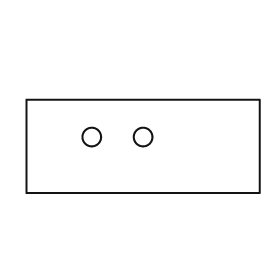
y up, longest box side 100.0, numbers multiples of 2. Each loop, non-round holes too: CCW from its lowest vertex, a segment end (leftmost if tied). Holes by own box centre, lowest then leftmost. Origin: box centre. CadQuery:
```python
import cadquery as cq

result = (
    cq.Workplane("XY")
    .moveTo(-50.0, -20.0)
    .lineTo(50.0, -20.0)
    .lineTo(50.0, 20.0)
    .lineTo(-50.0, 20.0)
    .close()
    .moveTo(-22.0, 4.0)
    .circle(4.0)
    .moveTo(0.0, 4.0)
    .circle(4.0)
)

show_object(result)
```